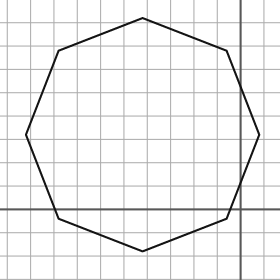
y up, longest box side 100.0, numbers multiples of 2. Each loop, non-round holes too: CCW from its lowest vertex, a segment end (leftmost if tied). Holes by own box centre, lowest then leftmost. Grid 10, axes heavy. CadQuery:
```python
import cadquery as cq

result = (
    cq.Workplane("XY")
    .moveTo(-42.0, -18.0)
    .lineTo(-6.0, -4.0)
    .lineTo(8.0, 32.0)
    .lineTo(-6.0, 68.0)
    .lineTo(-42.0, 82.0)
    .lineTo(-78.0, 68.0)
    .lineTo(-92.0, 32.0)
    .lineTo(-78.0, -4.0)
    .close()
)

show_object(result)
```